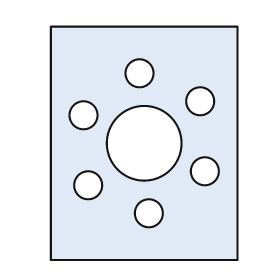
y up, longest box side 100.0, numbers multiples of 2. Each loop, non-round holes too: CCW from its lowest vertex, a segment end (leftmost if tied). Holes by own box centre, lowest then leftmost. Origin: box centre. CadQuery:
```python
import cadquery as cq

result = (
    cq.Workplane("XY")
    .moveTo(-40.0, -50.0)
    .lineTo(40.0, -50.0)
    .lineTo(40.0, 50.0)
    .lineTo(-40.0, 50.0)
    .close()
    .moveTo(2.0, -30.0)
    .circle(6.0)
    .moveTo(-24.0, -18.0)
    .circle(6.0)
    .moveTo(26.0, -12.0)
    .circle(6.0)
    .moveTo(0.0, 0.0)
    .circle(16.0)
    .moveTo(-26.0, 12.0)
    .circle(6.0)
    .moveTo(24.0, 18.0)
    .circle(6.0)
    .moveTo(-2.0, 30.0)
    .circle(6.0)
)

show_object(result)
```